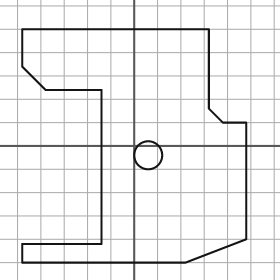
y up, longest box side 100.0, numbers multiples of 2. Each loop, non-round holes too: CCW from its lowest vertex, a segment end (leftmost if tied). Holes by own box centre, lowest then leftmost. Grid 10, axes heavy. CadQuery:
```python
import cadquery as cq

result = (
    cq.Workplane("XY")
    .moveTo(-48.0, -50.0)
    .lineTo(22.0, -50.0)
    .lineTo(48.0, -40.0)
    .lineTo(48.0, 10.0)
    .lineTo(38.0, 10.0)
    .lineTo(32.0, 16.0)
    .lineTo(32.0, 50.0)
    .lineTo(-48.0, 50.0)
    .lineTo(-48.0, 34.0)
    .lineTo(-38.0, 24.0)
    .lineTo(-14.0, 24.0)
    .lineTo(-14.0, -42.0)
    .lineTo(-48.0, -42.0)
    .close()
    .moveTo(6.0, -4.0)
    .circle(6.0)
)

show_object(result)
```